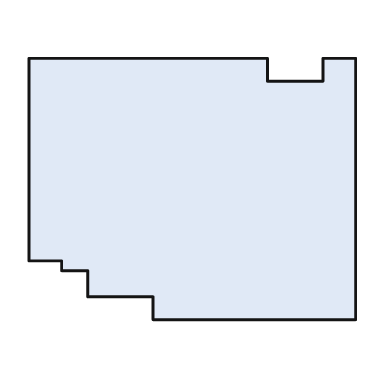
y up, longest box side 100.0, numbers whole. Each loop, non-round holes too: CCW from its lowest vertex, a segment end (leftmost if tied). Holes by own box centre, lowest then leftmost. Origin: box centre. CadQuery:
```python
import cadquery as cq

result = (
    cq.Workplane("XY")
    .moveTo(-12.0, -40.0)
    .lineTo(50.0, -40.0)
    .lineTo(50.0, 40.0)
    .lineTo(40.0, 40.0)
    .lineTo(40.0, 33.0)
    .lineTo(23.0, 33.0)
    .lineTo(23.0, 40.0)
    .lineTo(-50.0, 40.0)
    .lineTo(-50.0, -22.0)
    .lineTo(-40.0, -22.0)
    .lineTo(-40.0, -25.0)
    .lineTo(-32.0, -25.0)
    .lineTo(-32.0, -33.0)
    .lineTo(-12.0, -33.0)
    .close()
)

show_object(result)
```